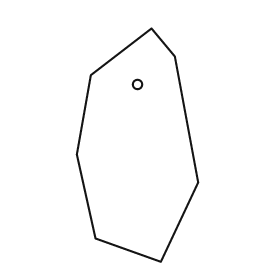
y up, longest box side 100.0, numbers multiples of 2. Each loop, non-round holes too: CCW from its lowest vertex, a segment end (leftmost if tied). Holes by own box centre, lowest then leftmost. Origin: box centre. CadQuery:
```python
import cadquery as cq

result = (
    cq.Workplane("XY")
    .moveTo(10.0, -50.0)
    .lineTo(26.0, -16.0)
    .lineTo(16.0, 38.0)
    .lineTo(6.0, 50.0)
    .lineTo(-20.0, 30.0)
    .lineTo(-26.0, -4.0)
    .lineTo(-18.0, -40.0)
    .close()
    .moveTo(0.0, 26.0)
    .circle(2.0)
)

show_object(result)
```